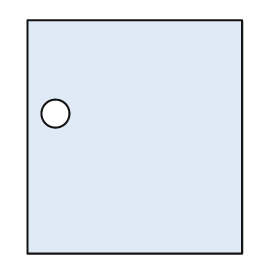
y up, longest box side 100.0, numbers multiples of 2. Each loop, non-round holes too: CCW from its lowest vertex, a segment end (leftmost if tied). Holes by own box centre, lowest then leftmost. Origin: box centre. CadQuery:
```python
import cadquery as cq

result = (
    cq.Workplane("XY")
    .moveTo(-46.0, -50.0)
    .lineTo(46.0, -50.0)
    .lineTo(46.0, 50.0)
    .lineTo(-46.0, 50.0)
    .close()
    .moveTo(-34.0, 10.0)
    .circle(6.0)
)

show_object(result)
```